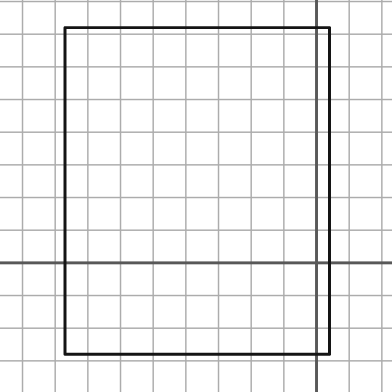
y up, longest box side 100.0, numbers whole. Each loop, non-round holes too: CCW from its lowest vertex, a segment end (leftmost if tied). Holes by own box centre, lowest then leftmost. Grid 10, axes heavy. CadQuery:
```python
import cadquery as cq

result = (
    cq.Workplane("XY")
    .moveTo(-77.0, -28.0)
    .lineTo(4.0, -28.0)
    .lineTo(4.0, 72.0)
    .lineTo(-77.0, 72.0)
    .close()
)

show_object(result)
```